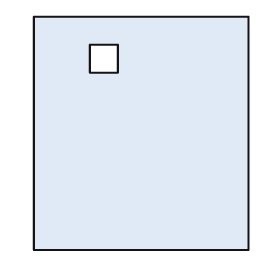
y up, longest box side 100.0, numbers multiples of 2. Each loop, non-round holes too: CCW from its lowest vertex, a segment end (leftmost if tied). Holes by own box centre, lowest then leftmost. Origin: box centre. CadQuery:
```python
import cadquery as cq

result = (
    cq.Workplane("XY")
    .moveTo(-46.0, -50.0)
    .lineTo(46.0, -50.0)
    .lineTo(46.0, 50.0)
    .lineTo(-46.0, 50.0)
    .close()
    .moveTo(-22.0, 26.0)
    .lineTo(-10.0, 26.0)
    .lineTo(-10.0, 38.0)
    .lineTo(-22.0, 38.0)
    .close()
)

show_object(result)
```